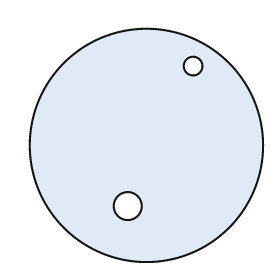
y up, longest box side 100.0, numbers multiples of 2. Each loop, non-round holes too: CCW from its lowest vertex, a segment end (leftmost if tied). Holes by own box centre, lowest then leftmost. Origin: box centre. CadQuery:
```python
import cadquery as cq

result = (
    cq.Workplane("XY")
    .moveTo(0.0, 0.0)
    .circle(50.0)
    .moveTo(-8.0, -26.0)
    .circle(6.0)
    .moveTo(20.0, 34.0)
    .circle(4.0)
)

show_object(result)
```